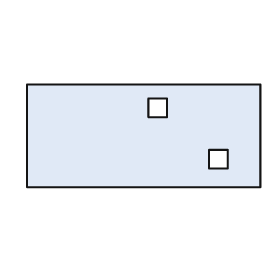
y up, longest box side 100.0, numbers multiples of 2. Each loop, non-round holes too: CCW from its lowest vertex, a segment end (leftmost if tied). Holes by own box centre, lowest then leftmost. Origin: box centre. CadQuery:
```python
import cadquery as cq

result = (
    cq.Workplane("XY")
    .moveTo(-50.0, -22.0)
    .lineTo(50.0, -22.0)
    .lineTo(50.0, 22.0)
    .lineTo(-50.0, 22.0)
    .close()
    .moveTo(28.0, -14.0)
    .lineTo(36.0, -14.0)
    .lineTo(36.0, -6.0)
    .lineTo(28.0, -6.0)
    .close()
    .moveTo(2.0, 8.0)
    .lineTo(10.0, 8.0)
    .lineTo(10.0, 16.0)
    .lineTo(2.0, 16.0)
    .close()
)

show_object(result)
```